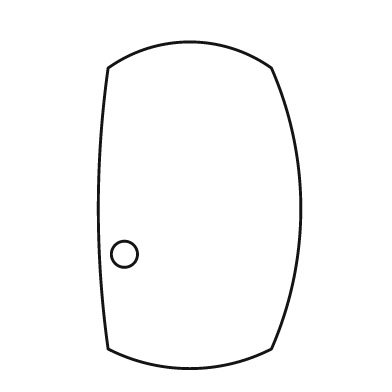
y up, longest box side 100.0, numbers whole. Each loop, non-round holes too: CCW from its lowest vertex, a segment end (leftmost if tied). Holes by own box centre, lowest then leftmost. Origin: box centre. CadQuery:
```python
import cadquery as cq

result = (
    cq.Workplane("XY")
    .moveTo(-28.0, -44.0)
    .threePointArc((-3.0, -50.0), (22.0, -44.0))
    .threePointArc((31.0, -1.0), (22.0, 42.0))
    .threePointArc((-3.0, 50.0), (-28.0, 42.0))
    .threePointArc((-31.0, -1.0), (-28.0, -44.0))
    .close()
    .moveTo(-23.0, -15.0)
    .circle(4.0)
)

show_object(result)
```